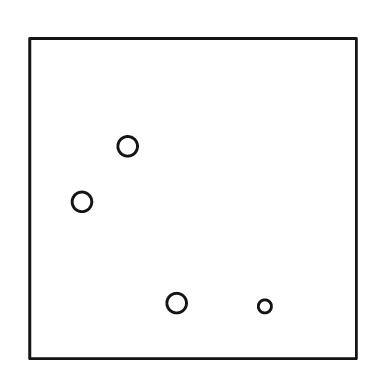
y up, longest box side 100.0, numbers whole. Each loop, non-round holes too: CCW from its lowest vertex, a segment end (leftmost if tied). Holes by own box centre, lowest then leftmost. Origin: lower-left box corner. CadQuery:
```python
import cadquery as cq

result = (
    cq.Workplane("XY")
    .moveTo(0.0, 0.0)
    .lineTo(100.0, 0.0)
    .lineTo(100.0, 98.0)
    .lineTo(0.0, 98.0)
    .close()
    .moveTo(72.0, 16.0)
    .circle(2.0)
    .moveTo(45.0, 17.0)
    .circle(3.0)
    .moveTo(16.0, 48.0)
    .circle(3.0)
    .moveTo(30.0, 65.0)
    .circle(3.0)
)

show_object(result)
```